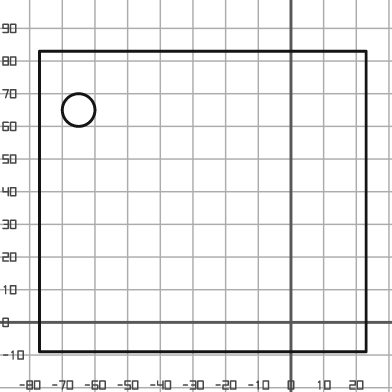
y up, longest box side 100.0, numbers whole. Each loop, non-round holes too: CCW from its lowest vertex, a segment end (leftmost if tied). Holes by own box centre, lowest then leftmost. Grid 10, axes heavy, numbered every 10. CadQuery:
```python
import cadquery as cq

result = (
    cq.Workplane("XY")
    .moveTo(-77.0, -9.0)
    .lineTo(23.0, -9.0)
    .lineTo(23.0, 83.0)
    .lineTo(-77.0, 83.0)
    .close()
    .moveTo(-65.0, 65.0)
    .circle(5.0)
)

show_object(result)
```